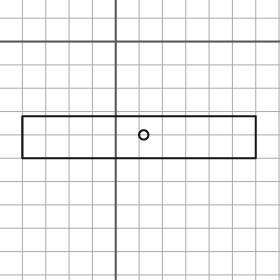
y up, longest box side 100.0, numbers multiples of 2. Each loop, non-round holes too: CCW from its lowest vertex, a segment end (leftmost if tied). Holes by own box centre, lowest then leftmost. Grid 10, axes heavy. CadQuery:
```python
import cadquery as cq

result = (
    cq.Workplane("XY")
    .moveTo(-40.0, -50.0)
    .lineTo(60.0, -50.0)
    .lineTo(60.0, -32.0)
    .lineTo(-40.0, -32.0)
    .close()
    .moveTo(12.0, -40.0)
    .circle(2.0)
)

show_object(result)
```